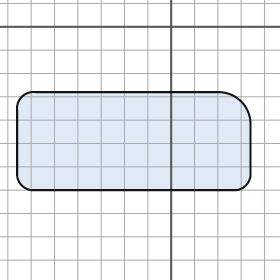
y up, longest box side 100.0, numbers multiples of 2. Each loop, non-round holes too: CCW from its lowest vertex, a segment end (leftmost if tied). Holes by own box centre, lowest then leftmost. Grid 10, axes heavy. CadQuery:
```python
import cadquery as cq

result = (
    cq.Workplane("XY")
    .moveTo(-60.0, -70.0)
    .lineTo(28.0, -70.0)
    .threePointArc((32.0, -68.0), (34.0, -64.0))
    .lineTo(34.0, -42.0)
    .threePointArc((30.0, -32.0), (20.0, -28.0))
    .lineTo(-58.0, -28.0)
    .threePointArc((-64.0, -30.0), (-66.0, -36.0))
    .lineTo(-66.0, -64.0)
    .threePointArc((-64.0, -68.0), (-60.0, -70.0))
    .close()
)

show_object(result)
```